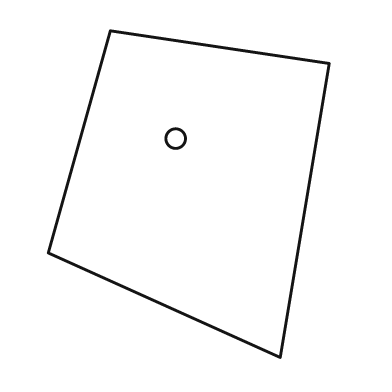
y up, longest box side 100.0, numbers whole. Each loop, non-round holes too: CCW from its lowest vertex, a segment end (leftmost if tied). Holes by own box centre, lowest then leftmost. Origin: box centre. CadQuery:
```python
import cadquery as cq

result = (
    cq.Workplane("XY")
    .moveTo(28.0, -50.0)
    .lineTo(43.0, 40.0)
    .lineTo(-24.0, 50.0)
    .lineTo(-43.0, -18.0)
    .close()
    .moveTo(-4.0, 17.0)
    .circle(3.0)
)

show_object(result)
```